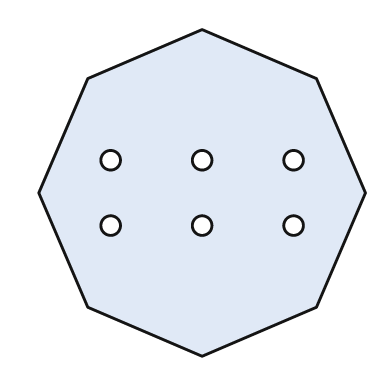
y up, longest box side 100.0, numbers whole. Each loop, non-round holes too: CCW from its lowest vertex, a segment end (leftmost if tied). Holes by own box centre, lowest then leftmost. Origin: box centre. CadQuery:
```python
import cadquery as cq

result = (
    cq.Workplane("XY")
    .moveTo(0.0, -50.0)
    .lineTo(35.0, -35.0)
    .lineTo(50.0, 0.0)
    .lineTo(35.0, 35.0)
    .lineTo(0.0, 50.0)
    .lineTo(-35.0, 35.0)
    .lineTo(-50.0, 0.0)
    .lineTo(-35.0, -35.0)
    .close()
    .moveTo(-28.0, -10.0)
    .circle(3.0)
    .moveTo(0.0, -10.0)
    .circle(3.0)
    .moveTo(28.0, -10.0)
    .circle(3.0)
    .moveTo(-28.0, 10.0)
    .circle(3.0)
    .moveTo(0.0, 10.0)
    .circle(3.0)
    .moveTo(28.0, 10.0)
    .circle(3.0)
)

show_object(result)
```